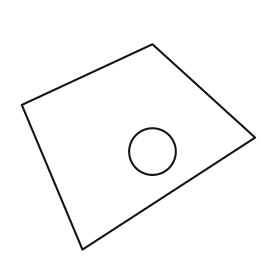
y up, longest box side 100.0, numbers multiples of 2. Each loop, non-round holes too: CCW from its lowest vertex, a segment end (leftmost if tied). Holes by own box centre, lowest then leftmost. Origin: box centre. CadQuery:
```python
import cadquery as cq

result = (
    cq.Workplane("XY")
    .moveTo(-24.0, -44.0)
    .lineTo(50.0, 4.0)
    .lineTo(6.0, 44.0)
    .lineTo(-50.0, 18.0)
    .close()
    .moveTo(6.0, -2.0)
    .circle(10.0)
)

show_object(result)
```